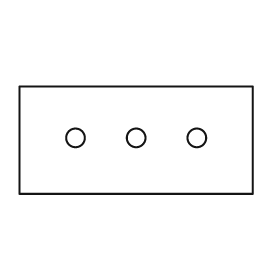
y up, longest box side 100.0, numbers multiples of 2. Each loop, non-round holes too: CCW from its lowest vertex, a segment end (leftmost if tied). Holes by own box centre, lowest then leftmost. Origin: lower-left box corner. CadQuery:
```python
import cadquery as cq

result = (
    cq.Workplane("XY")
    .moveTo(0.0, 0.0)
    .lineTo(100.0, 0.0)
    .lineTo(100.0, 46.0)
    .lineTo(0.0, 46.0)
    .close()
    .moveTo(24.0, 24.0)
    .circle(4.0)
    .moveTo(50.0, 24.0)
    .circle(4.0)
    .moveTo(76.0, 24.0)
    .circle(4.0)
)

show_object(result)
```